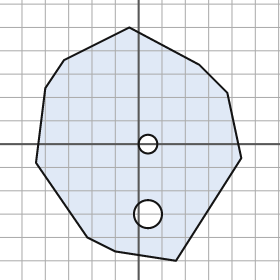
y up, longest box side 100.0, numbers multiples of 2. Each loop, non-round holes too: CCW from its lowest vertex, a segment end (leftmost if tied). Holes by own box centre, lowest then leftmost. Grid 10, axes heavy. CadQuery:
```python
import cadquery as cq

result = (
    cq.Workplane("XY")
    .moveTo(16.0, -50.0)
    .lineTo(44.0, -6.0)
    .lineTo(38.0, 22.0)
    .lineTo(26.0, 34.0)
    .lineTo(-4.0, 50.0)
    .lineTo(-32.0, 36.0)
    .lineTo(-40.0, 24.0)
    .lineTo(-44.0, -8.0)
    .lineTo(-22.0, -40.0)
    .lineTo(-10.0, -46.0)
    .close()
    .moveTo(4.0, -30.0)
    .circle(6.0)
    .moveTo(4.0, 0.0)
    .circle(4.0)
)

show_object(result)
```